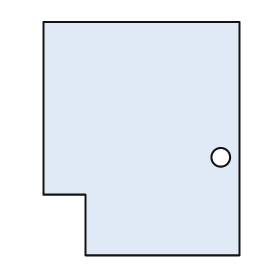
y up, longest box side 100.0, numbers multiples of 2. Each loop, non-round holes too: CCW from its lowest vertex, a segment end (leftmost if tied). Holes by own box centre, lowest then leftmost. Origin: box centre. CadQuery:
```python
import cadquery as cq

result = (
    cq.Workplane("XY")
    .moveTo(-24.0, -50.0)
    .lineTo(42.0, -50.0)
    .lineTo(42.0, 50.0)
    .lineTo(-42.0, 50.0)
    .lineTo(-42.0, -24.0)
    .lineTo(-24.0, -24.0)
    .close()
    .moveTo(34.0, -8.0)
    .circle(4.0)
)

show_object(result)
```